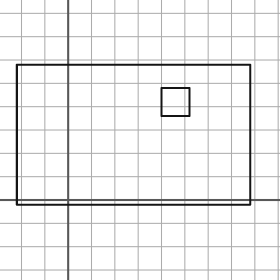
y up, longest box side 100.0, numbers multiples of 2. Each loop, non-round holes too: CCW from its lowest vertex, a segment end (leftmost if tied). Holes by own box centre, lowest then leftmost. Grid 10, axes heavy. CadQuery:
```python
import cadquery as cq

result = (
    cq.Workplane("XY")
    .moveTo(-22.0, -2.0)
    .lineTo(78.0, -2.0)
    .lineTo(78.0, 58.0)
    .lineTo(-22.0, 58.0)
    .close()
    .moveTo(40.0, 36.0)
    .lineTo(52.0, 36.0)
    .lineTo(52.0, 48.0)
    .lineTo(40.0, 48.0)
    .close()
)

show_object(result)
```